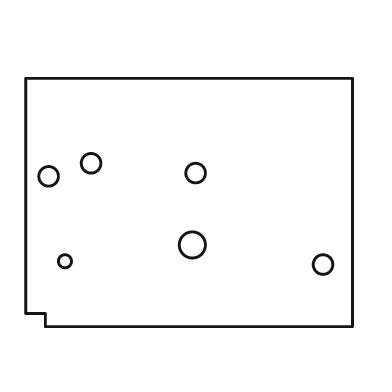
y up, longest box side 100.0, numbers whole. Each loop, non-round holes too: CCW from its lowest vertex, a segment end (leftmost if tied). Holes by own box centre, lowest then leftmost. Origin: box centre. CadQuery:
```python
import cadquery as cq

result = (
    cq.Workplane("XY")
    .moveTo(-44.0, -38.0)
    .lineTo(50.0, -38.0)
    .lineTo(50.0, 38.0)
    .lineTo(-50.0, 38.0)
    .lineTo(-50.0, -34.0)
    .lineTo(-44.0, -34.0)
    .close()
    .moveTo(41.0, -19.0)
    .circle(3.0)
    .moveTo(-38.0, -18.0)
    .circle(2.0)
    .moveTo(1.0, -13.0)
    .circle(4.0)
    .moveTo(-43.0, 8.0)
    .circle(3.0)
    .moveTo(2.0, 9.0)
    .circle(3.0)
    .moveTo(-30.0, 12.0)
    .circle(3.0)
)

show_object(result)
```